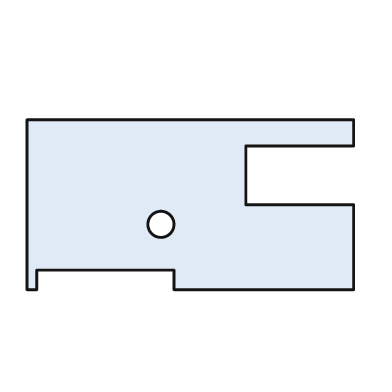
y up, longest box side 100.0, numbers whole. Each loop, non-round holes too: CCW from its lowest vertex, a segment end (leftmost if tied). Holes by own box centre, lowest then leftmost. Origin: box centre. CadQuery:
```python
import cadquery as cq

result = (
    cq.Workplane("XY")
    .moveTo(-50.0, -26.0)
    .lineTo(-47.0, -26.0)
    .lineTo(-47.0, -20.0)
    .lineTo(-5.0, -20.0)
    .lineTo(-5.0, -26.0)
    .lineTo(50.0, -26.0)
    .lineTo(50.0, 0.0)
    .lineTo(17.0, 0.0)
    .lineTo(17.0, 18.0)
    .lineTo(50.0, 18.0)
    .lineTo(50.0, 26.0)
    .lineTo(-50.0, 26.0)
    .close()
    .moveTo(-9.0, -6.0)
    .circle(4.0)
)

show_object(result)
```